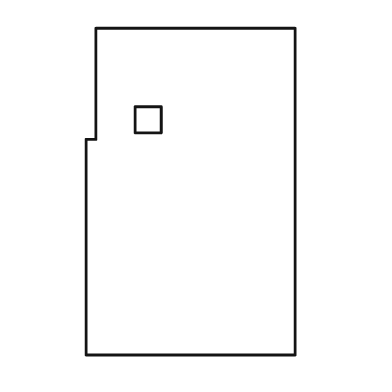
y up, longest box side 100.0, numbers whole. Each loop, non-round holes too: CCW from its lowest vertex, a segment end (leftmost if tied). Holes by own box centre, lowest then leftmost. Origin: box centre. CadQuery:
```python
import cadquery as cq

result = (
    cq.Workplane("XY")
    .moveTo(-32.0, -50.0)
    .lineTo(32.0, -50.0)
    .lineTo(32.0, 50.0)
    .lineTo(-29.0, 50.0)
    .lineTo(-29.0, 16.0)
    .lineTo(-32.0, 16.0)
    .close()
    .moveTo(-17.0, 18.0)
    .lineTo(-9.0, 18.0)
    .lineTo(-9.0, 26.0)
    .lineTo(-17.0, 26.0)
    .close()
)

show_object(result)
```